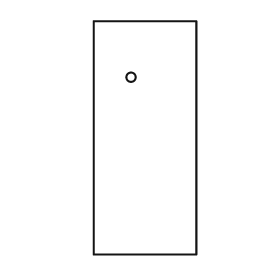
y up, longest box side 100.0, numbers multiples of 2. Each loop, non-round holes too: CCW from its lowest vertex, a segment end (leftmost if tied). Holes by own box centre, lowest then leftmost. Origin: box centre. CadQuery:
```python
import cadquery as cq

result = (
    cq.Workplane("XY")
    .moveTo(-22.0, -50.0)
    .lineTo(22.0, -50.0)
    .lineTo(22.0, 50.0)
    .lineTo(-22.0, 50.0)
    .close()
    .moveTo(-6.0, 26.0)
    .circle(2.0)
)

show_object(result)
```